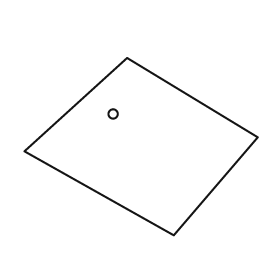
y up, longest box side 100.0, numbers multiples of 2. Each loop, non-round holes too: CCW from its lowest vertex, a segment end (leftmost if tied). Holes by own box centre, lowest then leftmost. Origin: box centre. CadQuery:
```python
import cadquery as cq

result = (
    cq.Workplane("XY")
    .moveTo(14.0, -38.0)
    .lineTo(50.0, 4.0)
    .lineTo(-6.0, 38.0)
    .lineTo(-50.0, -2.0)
    .close()
    .moveTo(-12.0, 14.0)
    .circle(2.0)
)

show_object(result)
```